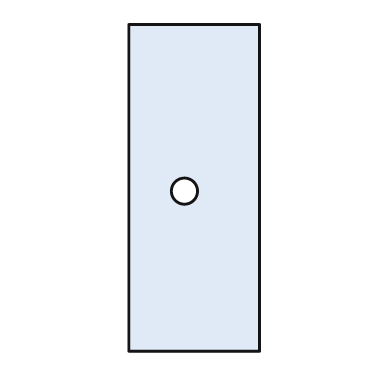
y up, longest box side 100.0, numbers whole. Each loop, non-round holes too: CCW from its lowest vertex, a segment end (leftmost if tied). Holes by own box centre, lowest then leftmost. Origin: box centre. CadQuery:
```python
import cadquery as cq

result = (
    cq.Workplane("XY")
    .moveTo(-20.0, -50.0)
    .lineTo(20.0, -50.0)
    .lineTo(20.0, 50.0)
    .lineTo(-20.0, 50.0)
    .close()
    .moveTo(-3.0, -1.0)
    .circle(4.0)
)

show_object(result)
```